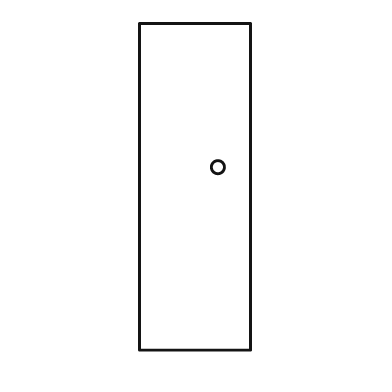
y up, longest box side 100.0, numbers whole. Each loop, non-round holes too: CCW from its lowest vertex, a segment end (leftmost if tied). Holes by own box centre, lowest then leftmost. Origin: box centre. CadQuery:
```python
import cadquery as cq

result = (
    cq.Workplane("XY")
    .moveTo(-17.0, -50.0)
    .lineTo(17.0, -50.0)
    .lineTo(17.0, 50.0)
    .lineTo(-17.0, 50.0)
    .close()
    .moveTo(7.0, 6.0)
    .circle(2.0)
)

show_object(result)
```